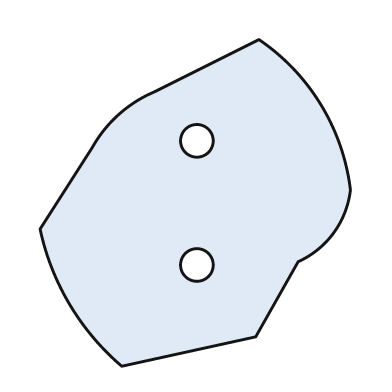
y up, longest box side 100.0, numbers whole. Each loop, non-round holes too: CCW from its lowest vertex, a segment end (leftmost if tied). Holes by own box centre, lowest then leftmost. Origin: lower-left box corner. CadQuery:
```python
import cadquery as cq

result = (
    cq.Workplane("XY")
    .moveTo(25.0, 0.0)
    .lineTo(66.0, 9.0)
    .lineTo(79.0, 32.0)
    .threePointArc((90.0, 41.0), (95.0, 54.0))
    .threePointArc((86.0, 80.0), (67.0, 100.0))
    .lineTo(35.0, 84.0)
    .threePointArc((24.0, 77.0), (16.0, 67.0))
    .lineTo(0.0, 42.0)
    .threePointArc((9.0, 19.0), (25.0, 0.0))
    .close()
    .moveTo(48.0, 31.0)
    .circle(5.0)
    .moveTo(48.0, 69.0)
    .circle(5.0)
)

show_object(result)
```